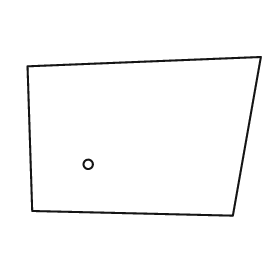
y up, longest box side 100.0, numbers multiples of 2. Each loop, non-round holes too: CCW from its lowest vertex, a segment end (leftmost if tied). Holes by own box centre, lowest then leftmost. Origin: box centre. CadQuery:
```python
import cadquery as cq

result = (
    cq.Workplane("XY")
    .moveTo(38.0, -34.0)
    .lineTo(50.0, 34.0)
    .lineTo(-50.0, 30.0)
    .lineTo(-48.0, -32.0)
    .close()
    .moveTo(-24.0, -12.0)
    .circle(2.0)
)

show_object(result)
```